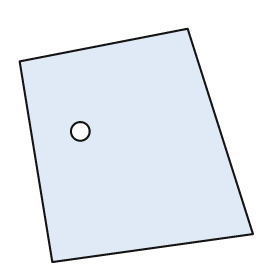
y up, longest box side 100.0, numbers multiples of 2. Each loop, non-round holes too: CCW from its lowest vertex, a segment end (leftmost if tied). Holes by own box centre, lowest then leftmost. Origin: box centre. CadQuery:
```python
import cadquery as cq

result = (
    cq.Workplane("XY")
    .moveTo(-36.0, -50.0)
    .lineTo(50.0, -38.0)
    .lineTo(22.0, 50.0)
    .lineTo(-50.0, 36.0)
    .close()
    .moveTo(-24.0, 6.0)
    .circle(4.0)
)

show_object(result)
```